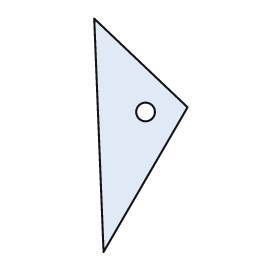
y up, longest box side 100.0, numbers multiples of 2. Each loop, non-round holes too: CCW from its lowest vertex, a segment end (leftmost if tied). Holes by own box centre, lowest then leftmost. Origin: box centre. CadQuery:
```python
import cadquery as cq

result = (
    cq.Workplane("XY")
    .moveTo(-16.0, -50.0)
    .lineTo(20.0, 12.0)
    .lineTo(-20.0, 50.0)
    .close()
    .moveTo(2.0, 10.0)
    .circle(4.0)
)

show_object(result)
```